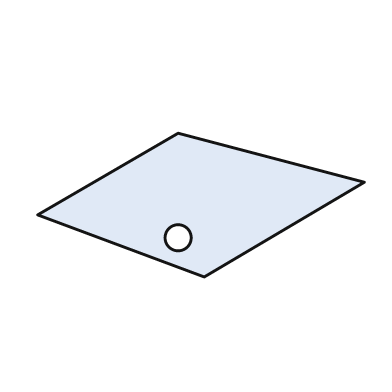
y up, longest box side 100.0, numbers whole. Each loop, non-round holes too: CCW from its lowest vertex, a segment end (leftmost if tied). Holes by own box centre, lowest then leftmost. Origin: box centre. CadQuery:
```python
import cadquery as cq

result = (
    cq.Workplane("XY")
    .moveTo(1.0, -22.0)
    .lineTo(50.0, 7.0)
    .lineTo(-7.0, 22.0)
    .lineTo(-50.0, -3.0)
    .close()
    .moveTo(-7.0, -10.0)
    .circle(4.0)
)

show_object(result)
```